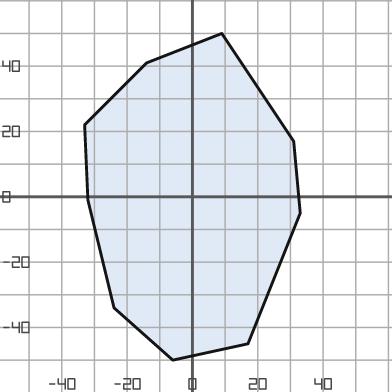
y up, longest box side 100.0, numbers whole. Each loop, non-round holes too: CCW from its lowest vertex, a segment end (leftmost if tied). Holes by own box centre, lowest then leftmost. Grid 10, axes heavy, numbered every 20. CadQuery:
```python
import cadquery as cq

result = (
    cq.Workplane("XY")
    .moveTo(-6.0, -50.0)
    .lineTo(17.0, -45.0)
    .lineTo(33.0, -5.0)
    .lineTo(31.0, 17.0)
    .lineTo(9.0, 50.0)
    .lineTo(-14.0, 41.0)
    .lineTo(-33.0, 22.0)
    .lineTo(-32.0, -1.0)
    .lineTo(-24.0, -34.0)
    .close()
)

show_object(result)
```